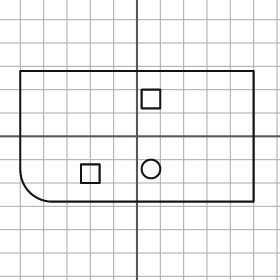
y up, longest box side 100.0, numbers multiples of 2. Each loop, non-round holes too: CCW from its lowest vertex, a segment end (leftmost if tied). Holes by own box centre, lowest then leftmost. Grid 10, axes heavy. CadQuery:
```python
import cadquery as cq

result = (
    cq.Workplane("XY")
    .moveTo(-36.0, -28.0)
    .lineTo(50.0, -28.0)
    .lineTo(50.0, 28.0)
    .lineTo(-50.0, 28.0)
    .lineTo(-50.0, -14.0)
    .threePointArc((-46.0, -24.0), (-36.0, -28.0))
    .close()
    .moveTo(-24.0, -20.0)
    .lineTo(-16.0, -20.0)
    .lineTo(-16.0, -12.0)
    .lineTo(-24.0, -12.0)
    .close()
    .moveTo(6.0, -14.0)
    .circle(4.0)
    .moveTo(2.0, 12.0)
    .lineTo(10.0, 12.0)
    .lineTo(10.0, 20.0)
    .lineTo(2.0, 20.0)
    .close()
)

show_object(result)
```